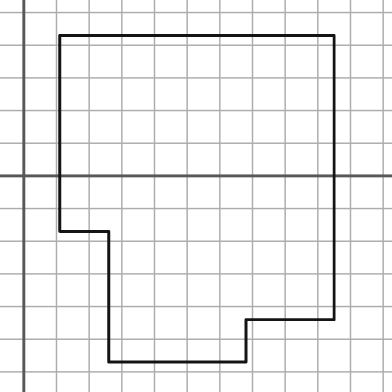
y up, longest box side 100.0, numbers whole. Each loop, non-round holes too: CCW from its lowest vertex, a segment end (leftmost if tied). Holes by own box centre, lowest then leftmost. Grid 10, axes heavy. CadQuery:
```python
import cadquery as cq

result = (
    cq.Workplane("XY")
    .moveTo(26.0, -57.0)
    .lineTo(68.0, -57.0)
    .lineTo(68.0, -44.0)
    .lineTo(95.0, -44.0)
    .lineTo(95.0, 43.0)
    .lineTo(11.0, 43.0)
    .lineTo(11.0, -17.0)
    .lineTo(26.0, -17.0)
    .close()
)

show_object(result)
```